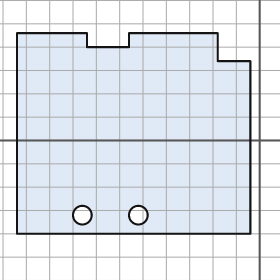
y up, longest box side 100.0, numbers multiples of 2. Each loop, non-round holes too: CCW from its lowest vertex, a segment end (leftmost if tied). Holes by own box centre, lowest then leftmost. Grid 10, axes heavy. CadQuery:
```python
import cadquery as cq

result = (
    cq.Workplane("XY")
    .moveTo(-104.0, -40.0)
    .lineTo(-4.0, -40.0)
    .lineTo(-4.0, 34.0)
    .lineTo(-18.0, 34.0)
    .lineTo(-18.0, 46.0)
    .lineTo(-56.0, 46.0)
    .lineTo(-56.0, 40.0)
    .lineTo(-74.0, 40.0)
    .lineTo(-74.0, 46.0)
    .lineTo(-104.0, 46.0)
    .close()
    .moveTo(-76.0, -32.0)
    .circle(4.0)
    .moveTo(-52.0, -32.0)
    .circle(4.0)
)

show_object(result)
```